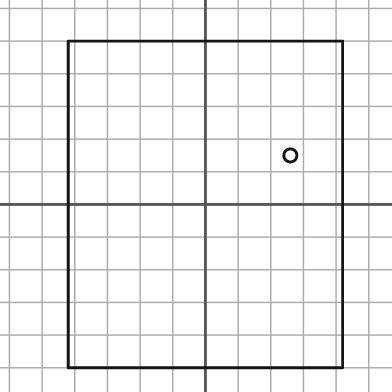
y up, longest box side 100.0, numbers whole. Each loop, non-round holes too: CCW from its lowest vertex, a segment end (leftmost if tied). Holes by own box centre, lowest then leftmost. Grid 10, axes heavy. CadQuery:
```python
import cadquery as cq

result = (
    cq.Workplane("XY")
    .moveTo(-42.0, -50.0)
    .lineTo(42.0, -50.0)
    .lineTo(42.0, 50.0)
    .lineTo(-42.0, 50.0)
    .close()
    .moveTo(26.0, 15.0)
    .circle(2.0)
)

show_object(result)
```